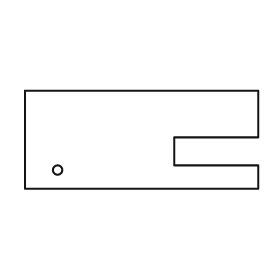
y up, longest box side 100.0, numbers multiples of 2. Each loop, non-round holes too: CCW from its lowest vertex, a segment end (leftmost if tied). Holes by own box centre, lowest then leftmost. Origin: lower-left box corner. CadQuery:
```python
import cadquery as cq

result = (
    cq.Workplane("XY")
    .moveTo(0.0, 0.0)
    .lineTo(100.0, 0.0)
    .lineTo(100.0, 10.0)
    .lineTo(64.0, 10.0)
    .lineTo(64.0, 22.0)
    .lineTo(100.0, 22.0)
    .lineTo(100.0, 42.0)
    .lineTo(0.0, 42.0)
    .close()
    .moveTo(14.0, 8.0)
    .circle(2.0)
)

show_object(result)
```